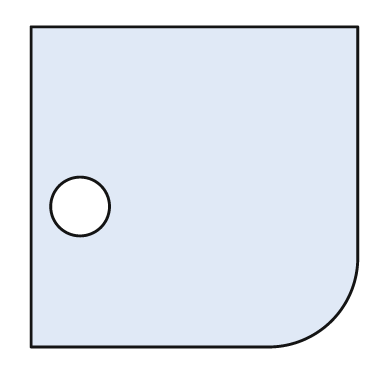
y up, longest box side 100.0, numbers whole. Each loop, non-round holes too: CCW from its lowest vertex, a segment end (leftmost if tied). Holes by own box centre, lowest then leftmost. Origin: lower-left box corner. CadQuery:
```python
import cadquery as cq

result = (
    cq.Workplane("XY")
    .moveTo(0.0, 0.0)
    .lineTo(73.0, 0.0)
    .threePointArc((92.0, 8.0), (100.0, 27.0))
    .lineTo(100.0, 98.0)
    .lineTo(0.0, 98.0)
    .close()
    .moveTo(15.0, 43.0)
    .circle(9.0)
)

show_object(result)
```